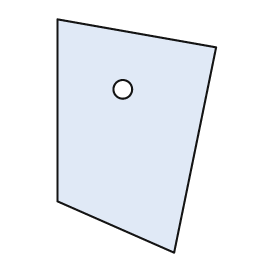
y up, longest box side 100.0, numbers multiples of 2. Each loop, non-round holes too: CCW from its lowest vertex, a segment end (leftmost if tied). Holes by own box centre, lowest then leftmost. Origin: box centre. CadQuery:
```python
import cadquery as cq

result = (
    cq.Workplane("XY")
    .moveTo(16.0, -50.0)
    .lineTo(34.0, 38.0)
    .lineTo(-34.0, 50.0)
    .lineTo(-34.0, -28.0)
    .close()
    .moveTo(-6.0, 20.0)
    .circle(4.0)
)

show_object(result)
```